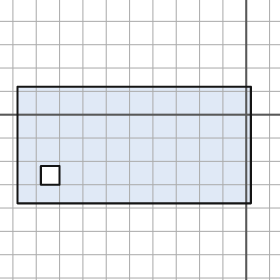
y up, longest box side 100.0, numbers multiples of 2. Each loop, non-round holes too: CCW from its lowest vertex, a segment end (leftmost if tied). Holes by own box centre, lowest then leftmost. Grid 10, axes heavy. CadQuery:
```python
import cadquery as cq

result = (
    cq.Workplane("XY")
    .moveTo(-98.0, -38.0)
    .lineTo(2.0, -38.0)
    .lineTo(2.0, 12.0)
    .lineTo(-98.0, 12.0)
    .close()
    .moveTo(-88.0, -30.0)
    .lineTo(-80.0, -30.0)
    .lineTo(-80.0, -22.0)
    .lineTo(-88.0, -22.0)
    .close()
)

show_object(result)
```